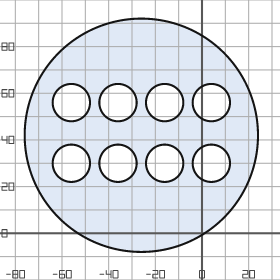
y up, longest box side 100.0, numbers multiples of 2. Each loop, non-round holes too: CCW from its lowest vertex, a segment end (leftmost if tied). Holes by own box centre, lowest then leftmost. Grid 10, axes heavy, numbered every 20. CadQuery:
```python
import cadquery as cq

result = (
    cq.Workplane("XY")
    .moveTo(-26.0, 42.0)
    .circle(50.0)
    .moveTo(-56.0, 30.0)
    .circle(8.0)
    .moveTo(-36.0, 30.0)
    .circle(8.0)
    .moveTo(-16.0, 30.0)
    .circle(8.0)
    .moveTo(4.0, 30.0)
    .circle(8.0)
    .moveTo(-56.0, 56.0)
    .circle(8.0)
    .moveTo(-36.0, 56.0)
    .circle(8.0)
    .moveTo(-16.0, 56.0)
    .circle(8.0)
    .moveTo(4.0, 56.0)
    .circle(8.0)
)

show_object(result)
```